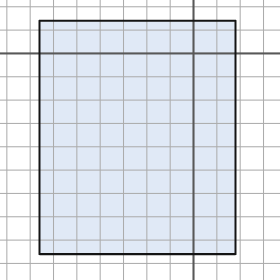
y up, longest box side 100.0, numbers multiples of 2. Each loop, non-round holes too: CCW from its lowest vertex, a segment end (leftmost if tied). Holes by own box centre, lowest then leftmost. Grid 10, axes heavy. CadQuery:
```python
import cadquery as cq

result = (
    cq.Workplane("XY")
    .moveTo(-66.0, -86.0)
    .lineTo(18.0, -86.0)
    .lineTo(18.0, 14.0)
    .lineTo(-66.0, 14.0)
    .close()
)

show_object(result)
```